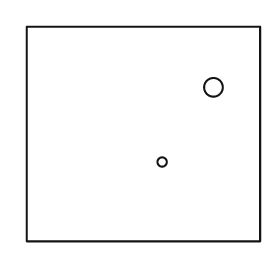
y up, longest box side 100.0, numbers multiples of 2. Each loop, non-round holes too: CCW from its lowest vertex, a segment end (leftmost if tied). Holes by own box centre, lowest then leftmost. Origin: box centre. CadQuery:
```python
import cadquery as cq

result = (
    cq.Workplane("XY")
    .moveTo(-50.0, -46.0)
    .lineTo(50.0, -46.0)
    .lineTo(50.0, 46.0)
    .lineTo(-50.0, 46.0)
    .close()
    .moveTo(8.0, -12.0)
    .circle(2.0)
    .moveTo(30.0, 20.0)
    .circle(4.0)
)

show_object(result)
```